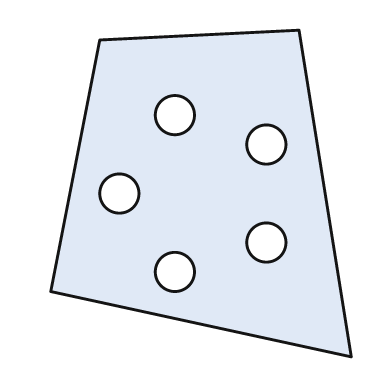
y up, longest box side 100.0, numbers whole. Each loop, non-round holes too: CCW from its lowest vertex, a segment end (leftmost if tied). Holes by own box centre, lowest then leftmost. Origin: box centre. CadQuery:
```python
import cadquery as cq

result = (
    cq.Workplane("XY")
    .moveTo(46.0, -50.0)
    .lineTo(30.0, 50.0)
    .lineTo(-31.0, 47.0)
    .lineTo(-46.0, -30.0)
    .close()
    .moveTo(-8.0, -24.0)
    .circle(6.0)
    .moveTo(20.0, -15.0)
    .circle(6.0)
    .moveTo(-25.0, 0.0)
    .circle(6.0)
    .moveTo(20.0, 15.0)
    .circle(6.0)
    .moveTo(-8.0, 24.0)
    .circle(6.0)
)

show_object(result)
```